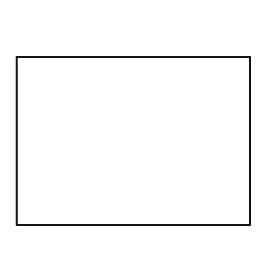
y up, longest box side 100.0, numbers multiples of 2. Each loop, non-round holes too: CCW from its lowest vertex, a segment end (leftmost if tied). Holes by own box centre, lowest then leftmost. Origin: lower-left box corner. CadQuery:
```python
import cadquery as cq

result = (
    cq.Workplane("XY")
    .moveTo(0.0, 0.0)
    .lineTo(100.0, 0.0)
    .lineTo(100.0, 72.0)
    .lineTo(0.0, 72.0)
    .close()
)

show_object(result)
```